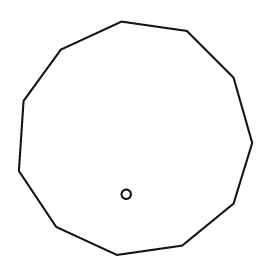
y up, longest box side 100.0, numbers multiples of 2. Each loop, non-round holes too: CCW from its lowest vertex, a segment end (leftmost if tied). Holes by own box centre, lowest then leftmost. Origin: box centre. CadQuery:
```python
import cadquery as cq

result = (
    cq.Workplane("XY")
    .moveTo(-8.0, -50.0)
    .lineTo(20.0, -46.0)
    .lineTo(42.0, -28.0)
    .lineTo(50.0, -2.0)
    .lineTo(42.0, 26.0)
    .lineTo(22.0, 46.0)
    .lineTo(-6.0, 50.0)
    .lineTo(-32.0, 38.0)
    .lineTo(-48.0, 16.0)
    .lineTo(-50.0, -14.0)
    .lineTo(-34.0, -38.0)
    .close()
    .moveTo(-4.0, -24.0)
    .circle(2.0)
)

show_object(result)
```